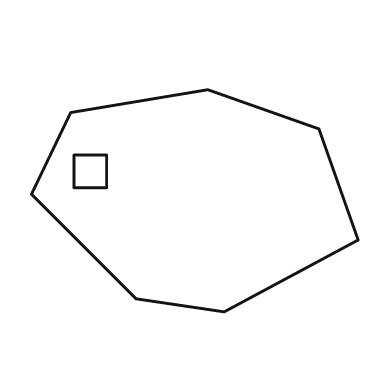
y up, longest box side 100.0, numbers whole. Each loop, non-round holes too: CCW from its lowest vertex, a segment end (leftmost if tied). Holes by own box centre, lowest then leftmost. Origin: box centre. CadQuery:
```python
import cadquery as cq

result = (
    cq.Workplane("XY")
    .moveTo(9.0, -34.0)
    .lineTo(50.0, -12.0)
    .lineTo(38.0, 22.0)
    .lineTo(4.0, 34.0)
    .lineTo(-38.0, 27.0)
    .lineTo(-50.0, 2.0)
    .lineTo(-18.0, -30.0)
    .close()
    .moveTo(-37.0, 4.0)
    .lineTo(-27.0, 4.0)
    .lineTo(-27.0, 14.0)
    .lineTo(-37.0, 14.0)
    .close()
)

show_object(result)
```